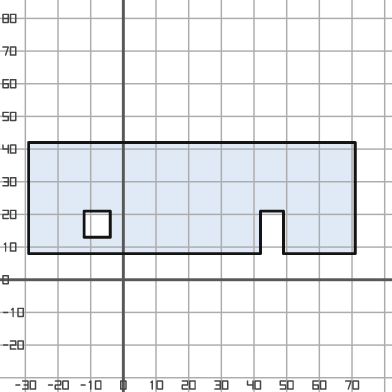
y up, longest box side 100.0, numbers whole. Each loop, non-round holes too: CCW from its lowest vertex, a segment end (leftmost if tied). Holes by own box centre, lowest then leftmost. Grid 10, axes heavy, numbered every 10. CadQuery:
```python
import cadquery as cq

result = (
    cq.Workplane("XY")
    .moveTo(-29.0, 8.0)
    .lineTo(42.0, 8.0)
    .lineTo(42.0, 21.0)
    .lineTo(49.0, 21.0)
    .lineTo(49.0, 8.0)
    .lineTo(71.0, 8.0)
    .lineTo(71.0, 42.0)
    .lineTo(-29.0, 42.0)
    .close()
    .moveTo(-12.0, 13.0)
    .lineTo(-4.0, 13.0)
    .lineTo(-4.0, 21.0)
    .lineTo(-12.0, 21.0)
    .close()
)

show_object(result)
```